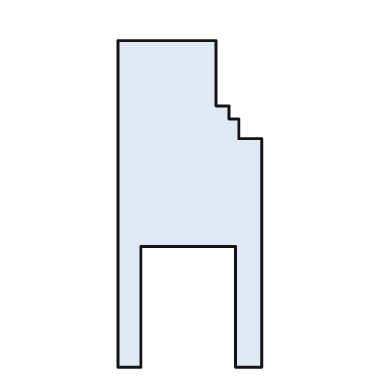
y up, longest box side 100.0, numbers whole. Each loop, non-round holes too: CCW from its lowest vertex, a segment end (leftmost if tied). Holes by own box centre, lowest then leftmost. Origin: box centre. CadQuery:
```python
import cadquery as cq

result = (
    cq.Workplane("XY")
    .moveTo(-22.0, -50.0)
    .lineTo(-15.0, -50.0)
    .lineTo(-15.0, -13.0)
    .lineTo(14.0, -13.0)
    .lineTo(14.0, -50.0)
    .lineTo(22.0, -50.0)
    .lineTo(22.0, 20.0)
    .lineTo(15.0, 20.0)
    .lineTo(15.0, 26.0)
    .lineTo(12.0, 26.0)
    .lineTo(12.0, 30.0)
    .lineTo(8.0, 30.0)
    .lineTo(8.0, 50.0)
    .lineTo(-22.0, 50.0)
    .close()
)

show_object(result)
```